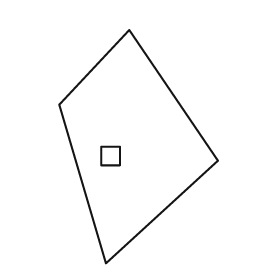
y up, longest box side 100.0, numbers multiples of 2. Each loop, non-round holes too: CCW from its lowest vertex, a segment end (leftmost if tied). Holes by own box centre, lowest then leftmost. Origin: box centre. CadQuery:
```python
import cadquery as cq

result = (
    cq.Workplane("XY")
    .moveTo(-14.0, -50.0)
    .lineTo(34.0, -6.0)
    .lineTo(-4.0, 50.0)
    .lineTo(-34.0, 18.0)
    .close()
    .moveTo(-16.0, -8.0)
    .lineTo(-8.0, -8.0)
    .lineTo(-8.0, 0.0)
    .lineTo(-16.0, 0.0)
    .close()
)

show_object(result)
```